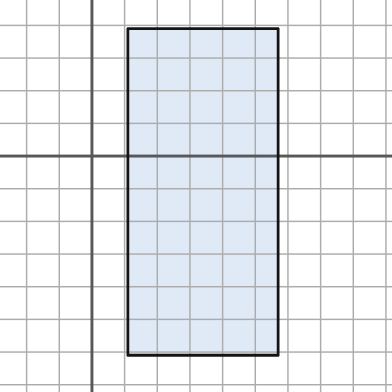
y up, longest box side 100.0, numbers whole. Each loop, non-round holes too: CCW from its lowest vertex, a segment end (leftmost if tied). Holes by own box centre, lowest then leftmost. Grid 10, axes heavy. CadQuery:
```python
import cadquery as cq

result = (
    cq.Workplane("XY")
    .moveTo(11.0, -61.0)
    .lineTo(57.0, -61.0)
    .lineTo(57.0, 39.0)
    .lineTo(11.0, 39.0)
    .close()
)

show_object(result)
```